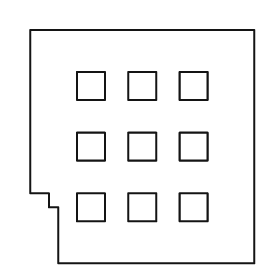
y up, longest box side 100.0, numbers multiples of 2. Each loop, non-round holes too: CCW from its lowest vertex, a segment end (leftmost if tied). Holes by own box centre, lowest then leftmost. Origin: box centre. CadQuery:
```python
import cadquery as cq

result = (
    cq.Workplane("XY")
    .moveTo(-36.0, -50.0)
    .lineTo(48.0, -50.0)
    .lineTo(48.0, 50.0)
    .lineTo(-48.0, 50.0)
    .lineTo(-48.0, -20.0)
    .lineTo(-40.0, -20.0)
    .lineTo(-40.0, -26.0)
    .lineTo(-36.0, -26.0)
    .close()
    .moveTo(-28.0, -32.0)
    .lineTo(-16.0, -32.0)
    .lineTo(-16.0, -20.0)
    .lineTo(-28.0, -20.0)
    .close()
    .moveTo(-6.0, -32.0)
    .lineTo(6.0, -32.0)
    .lineTo(6.0, -20.0)
    .lineTo(-6.0, -20.0)
    .close()
    .moveTo(16.0, -32.0)
    .lineTo(28.0, -32.0)
    .lineTo(28.0, -20.0)
    .lineTo(16.0, -20.0)
    .close()
    .moveTo(-28.0, -6.0)
    .lineTo(-16.0, -6.0)
    .lineTo(-16.0, 6.0)
    .lineTo(-28.0, 6.0)
    .close()
    .moveTo(-6.0, -6.0)
    .lineTo(6.0, -6.0)
    .lineTo(6.0, 6.0)
    .lineTo(-6.0, 6.0)
    .close()
    .moveTo(16.0, -6.0)
    .lineTo(28.0, -6.0)
    .lineTo(28.0, 6.0)
    .lineTo(16.0, 6.0)
    .close()
    .moveTo(-28.0, 20.0)
    .lineTo(-16.0, 20.0)
    .lineTo(-16.0, 32.0)
    .lineTo(-28.0, 32.0)
    .close()
    .moveTo(-6.0, 20.0)
    .lineTo(6.0, 20.0)
    .lineTo(6.0, 32.0)
    .lineTo(-6.0, 32.0)
    .close()
    .moveTo(16.0, 20.0)
    .lineTo(28.0, 20.0)
    .lineTo(28.0, 32.0)
    .lineTo(16.0, 32.0)
    .close()
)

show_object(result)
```